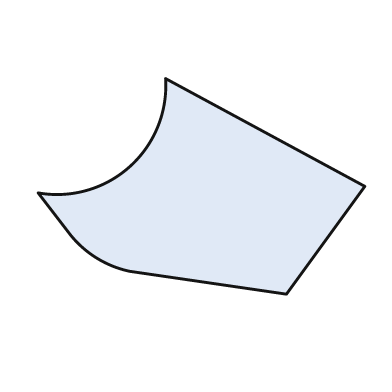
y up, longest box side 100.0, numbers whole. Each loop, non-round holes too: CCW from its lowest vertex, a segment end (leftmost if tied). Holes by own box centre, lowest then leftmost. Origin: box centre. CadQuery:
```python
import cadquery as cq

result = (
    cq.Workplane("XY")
    .moveTo(26.0, -33.0)
    .lineTo(50.0, 0.0)
    .lineTo(-11.0, 33.0)
    .threePointArc((-22.0, 6.0), (-50.0, -2.0))
    .lineTo(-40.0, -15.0)
    .threePointArc((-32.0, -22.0), (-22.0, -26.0))
    .close()
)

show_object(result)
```